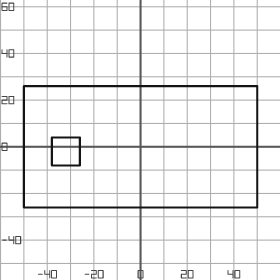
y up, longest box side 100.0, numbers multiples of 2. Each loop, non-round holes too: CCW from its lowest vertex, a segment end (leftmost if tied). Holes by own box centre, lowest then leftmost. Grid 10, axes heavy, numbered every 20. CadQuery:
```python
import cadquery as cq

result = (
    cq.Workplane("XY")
    .moveTo(-50.0, -26.0)
    .lineTo(50.0, -26.0)
    .lineTo(50.0, 26.0)
    .lineTo(-50.0, 26.0)
    .close()
    .moveTo(-38.0, -8.0)
    .lineTo(-26.0, -8.0)
    .lineTo(-26.0, 4.0)
    .lineTo(-38.0, 4.0)
    .close()
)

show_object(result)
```